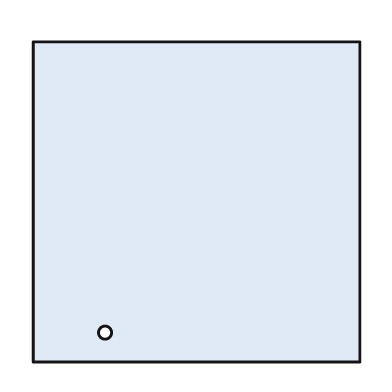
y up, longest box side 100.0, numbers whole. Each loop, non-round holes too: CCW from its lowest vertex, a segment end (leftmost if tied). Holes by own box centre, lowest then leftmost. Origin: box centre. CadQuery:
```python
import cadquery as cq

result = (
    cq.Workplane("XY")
    .moveTo(-50.0, -49.0)
    .lineTo(50.0, -49.0)
    .lineTo(50.0, 49.0)
    .lineTo(-50.0, 49.0)
    .close()
    .moveTo(-28.0, -40.0)
    .circle(2.0)
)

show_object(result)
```